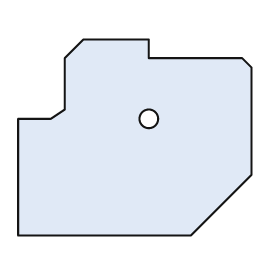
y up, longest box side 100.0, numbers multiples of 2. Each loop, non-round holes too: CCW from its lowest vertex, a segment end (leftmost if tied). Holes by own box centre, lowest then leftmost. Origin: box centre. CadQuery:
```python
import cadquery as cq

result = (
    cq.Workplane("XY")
    .moveTo(-50.0, -42.0)
    .lineTo(24.0, -42.0)
    .lineTo(50.0, -16.0)
    .lineTo(50.0, 30.0)
    .lineTo(46.0, 34.0)
    .lineTo(6.0, 34.0)
    .lineTo(6.0, 42.0)
    .lineTo(-22.0, 42.0)
    .lineTo(-30.0, 34.0)
    .lineTo(-30.0, 12.0)
    .lineTo(-36.0, 8.0)
    .lineTo(-50.0, 8.0)
    .close()
    .moveTo(6.0, 8.0)
    .circle(4.0)
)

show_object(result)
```